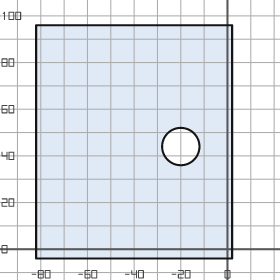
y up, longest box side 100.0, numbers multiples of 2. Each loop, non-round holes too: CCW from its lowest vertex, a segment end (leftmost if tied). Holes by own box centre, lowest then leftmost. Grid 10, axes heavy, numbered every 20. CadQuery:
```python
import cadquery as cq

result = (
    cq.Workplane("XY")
    .moveTo(-82.0, -4.0)
    .lineTo(2.0, -4.0)
    .lineTo(2.0, 96.0)
    .lineTo(-82.0, 96.0)
    .close()
    .moveTo(-20.0, 44.0)
    .circle(8.0)
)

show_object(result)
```